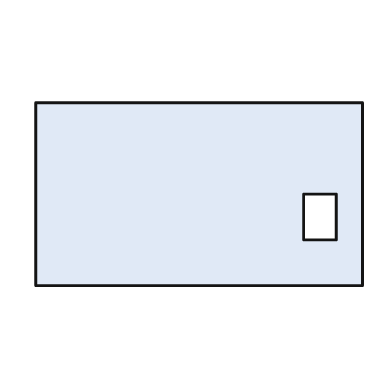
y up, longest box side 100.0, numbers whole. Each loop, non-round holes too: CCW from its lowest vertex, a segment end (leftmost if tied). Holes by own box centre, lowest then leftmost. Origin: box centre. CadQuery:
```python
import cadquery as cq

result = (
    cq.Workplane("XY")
    .moveTo(-50.0, -28.0)
    .lineTo(50.0, -28.0)
    .lineTo(50.0, 28.0)
    .lineTo(-50.0, 28.0)
    .close()
    .moveTo(32.0, -14.0)
    .lineTo(42.0, -14.0)
    .lineTo(42.0, 0.0)
    .lineTo(32.0, 0.0)
    .close()
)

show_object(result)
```